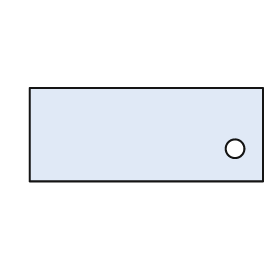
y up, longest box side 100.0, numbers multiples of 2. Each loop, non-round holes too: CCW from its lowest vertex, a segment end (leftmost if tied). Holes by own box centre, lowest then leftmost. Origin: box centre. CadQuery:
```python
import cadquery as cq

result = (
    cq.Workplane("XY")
    .moveTo(-50.0, -20.0)
    .lineTo(50.0, -20.0)
    .lineTo(50.0, 20.0)
    .lineTo(-50.0, 20.0)
    .close()
    .moveTo(38.0, -6.0)
    .circle(4.0)
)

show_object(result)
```